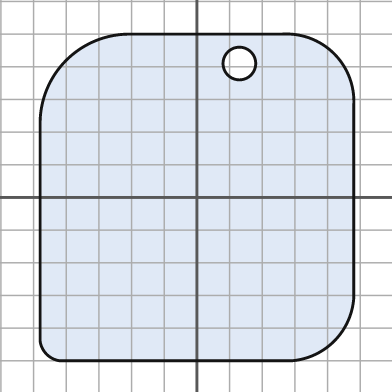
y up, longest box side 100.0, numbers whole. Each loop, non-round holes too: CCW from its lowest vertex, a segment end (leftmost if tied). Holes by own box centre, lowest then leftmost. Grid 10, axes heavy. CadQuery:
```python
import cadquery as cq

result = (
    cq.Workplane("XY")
    .moveTo(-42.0, -50.0)
    .lineTo(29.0, -50.0)
    .threePointArc((42.0, -44.0), (48.0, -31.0))
    .lineTo(48.0, 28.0)
    .threePointArc((42.0, 44.0), (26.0, 50.0))
    .lineTo(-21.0, 50.0)
    .threePointArc((-40.0, 42.0), (-48.0, 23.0))
    .lineTo(-48.0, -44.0)
    .threePointArc((-46.0, -48.0), (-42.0, -50.0))
    .close()
    .moveTo(13.0, 41.0)
    .circle(5.0)
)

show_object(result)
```